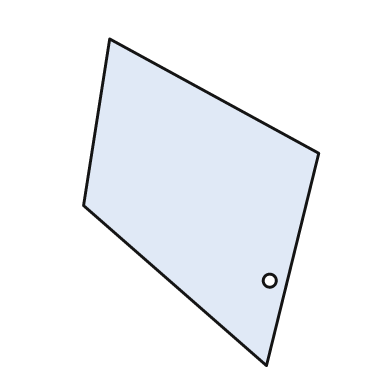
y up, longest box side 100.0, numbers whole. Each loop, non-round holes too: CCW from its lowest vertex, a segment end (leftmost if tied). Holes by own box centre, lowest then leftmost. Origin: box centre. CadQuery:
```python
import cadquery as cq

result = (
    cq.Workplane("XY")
    .moveTo(20.0, -50.0)
    .lineTo(36.0, 15.0)
    .lineTo(-28.0, 50.0)
    .lineTo(-36.0, -1.0)
    .close()
    .moveTo(21.0, -24.0)
    .circle(2.0)
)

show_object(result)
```